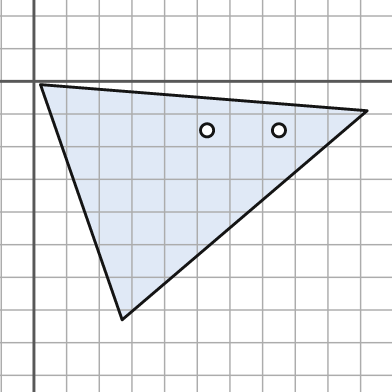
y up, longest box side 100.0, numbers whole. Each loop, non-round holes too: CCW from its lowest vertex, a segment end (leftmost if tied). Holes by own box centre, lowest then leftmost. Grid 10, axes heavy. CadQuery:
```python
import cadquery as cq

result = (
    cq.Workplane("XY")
    .moveTo(27.0, -73.0)
    .lineTo(102.0, -9.0)
    .lineTo(2.0, -1.0)
    .close()
    .moveTo(53.0, -15.0)
    .circle(2.0)
    .moveTo(75.0, -15.0)
    .circle(2.0)
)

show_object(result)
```